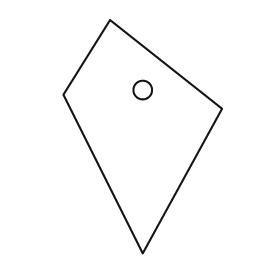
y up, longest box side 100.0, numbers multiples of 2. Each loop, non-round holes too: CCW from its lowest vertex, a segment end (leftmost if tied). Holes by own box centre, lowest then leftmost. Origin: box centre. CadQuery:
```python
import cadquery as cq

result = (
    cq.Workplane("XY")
    .moveTo(0.0, -50.0)
    .lineTo(34.0, 12.0)
    .lineTo(-14.0, 50.0)
    .lineTo(-34.0, 18.0)
    .close()
    .moveTo(0.0, 20.0)
    .circle(4.0)
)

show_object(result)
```